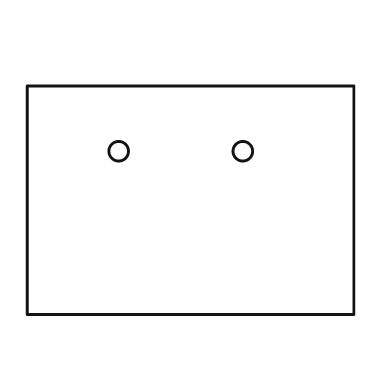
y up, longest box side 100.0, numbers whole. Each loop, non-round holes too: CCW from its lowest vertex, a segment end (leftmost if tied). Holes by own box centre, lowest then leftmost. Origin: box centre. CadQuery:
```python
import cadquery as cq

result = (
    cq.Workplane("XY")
    .moveTo(-50.0, -35.0)
    .lineTo(50.0, -35.0)
    .lineTo(50.0, 35.0)
    .lineTo(-50.0, 35.0)
    .close()
    .moveTo(-22.0, 15.0)
    .circle(3.0)
    .moveTo(16.0, 15.0)
    .circle(3.0)
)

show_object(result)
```